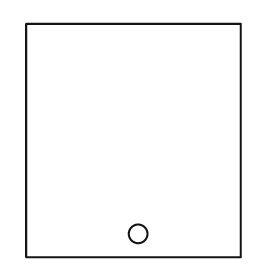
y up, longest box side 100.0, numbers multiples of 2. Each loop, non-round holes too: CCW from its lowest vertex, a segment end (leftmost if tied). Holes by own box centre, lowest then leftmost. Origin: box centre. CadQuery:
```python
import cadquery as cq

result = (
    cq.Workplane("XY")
    .moveTo(-46.0, -50.0)
    .lineTo(46.0, -50.0)
    .lineTo(46.0, 50.0)
    .lineTo(-46.0, 50.0)
    .close()
    .moveTo(2.0, -40.0)
    .circle(4.0)
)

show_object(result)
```